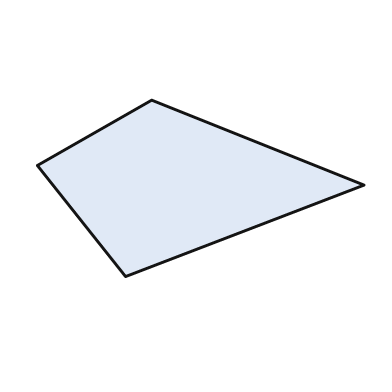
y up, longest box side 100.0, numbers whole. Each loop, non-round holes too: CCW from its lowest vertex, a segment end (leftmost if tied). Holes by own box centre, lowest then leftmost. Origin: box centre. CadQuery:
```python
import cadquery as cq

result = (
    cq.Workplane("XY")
    .moveTo(-23.0, -27.0)
    .lineTo(50.0, 1.0)
    .lineTo(-15.0, 27.0)
    .lineTo(-50.0, 7.0)
    .close()
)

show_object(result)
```